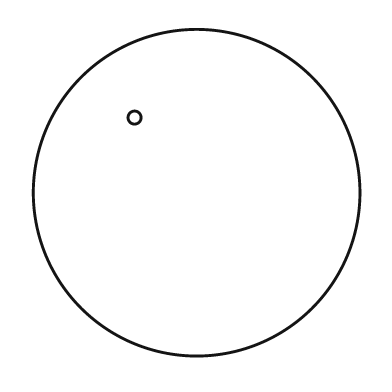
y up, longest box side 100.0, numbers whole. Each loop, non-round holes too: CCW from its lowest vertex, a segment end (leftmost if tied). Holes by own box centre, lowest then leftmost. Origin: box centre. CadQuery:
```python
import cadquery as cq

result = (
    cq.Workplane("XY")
    .moveTo(0.0, 0.0)
    .circle(50.0)
    .moveTo(-19.0, 23.0)
    .circle(2.0)
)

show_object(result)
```